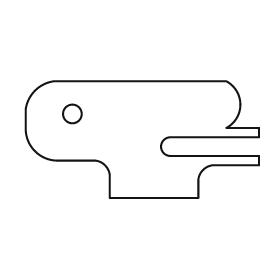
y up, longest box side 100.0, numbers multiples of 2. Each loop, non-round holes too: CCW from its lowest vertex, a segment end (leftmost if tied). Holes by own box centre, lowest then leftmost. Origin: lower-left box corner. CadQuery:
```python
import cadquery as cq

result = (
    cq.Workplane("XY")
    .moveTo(36.0, 0.0)
    .lineTo(74.0, 0.0)
    .lineTo(74.0, 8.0)
    .threePointArc((76.0, 12.0), (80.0, 14.0))
    .lineTo(100.0, 14.0)
    .lineTo(100.0, 18.0)
    .lineTo(62.0, 18.0)
    .threePointArc((58.0, 22.0), (62.0, 26.0))
    .lineTo(100.0, 26.0)
    .lineTo(100.0, 30.0)
    .lineTo(86.0, 30.0)
    .threePointArc((92.0, 40.0), (86.0, 50.0))
    .lineTo(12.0, 50.0)
    .threePointArc((4.0, 46.0), (0.0, 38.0))
    .lineTo(0.0, 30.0)
    .threePointArc((4.0, 20.0), (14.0, 16.0))
    .lineTo(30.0, 16.0)
    .threePointArc((34.0, 14.0), (36.0, 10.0))
    .close()
    .moveTo(20.0, 36.0)
    .circle(4.0)
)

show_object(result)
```